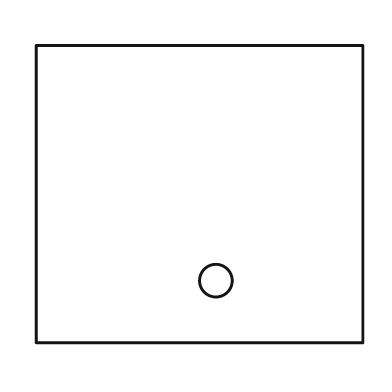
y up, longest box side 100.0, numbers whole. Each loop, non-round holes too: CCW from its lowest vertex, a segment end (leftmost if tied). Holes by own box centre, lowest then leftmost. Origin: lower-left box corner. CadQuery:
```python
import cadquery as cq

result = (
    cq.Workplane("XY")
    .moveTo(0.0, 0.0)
    .lineTo(100.0, 0.0)
    .lineTo(100.0, 91.0)
    .lineTo(0.0, 91.0)
    .close()
    .moveTo(55.0, 19.0)
    .circle(5.0)
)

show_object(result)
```